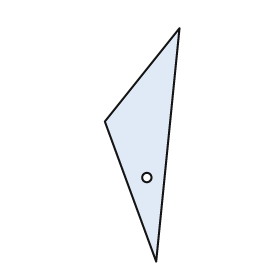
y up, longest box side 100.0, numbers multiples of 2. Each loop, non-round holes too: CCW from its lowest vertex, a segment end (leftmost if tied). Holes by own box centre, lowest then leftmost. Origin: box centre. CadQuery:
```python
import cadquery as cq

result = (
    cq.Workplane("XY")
    .moveTo(6.0, -50.0)
    .lineTo(16.0, 50.0)
    .lineTo(-16.0, 10.0)
    .close()
    .moveTo(2.0, -14.0)
    .circle(2.0)
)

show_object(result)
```